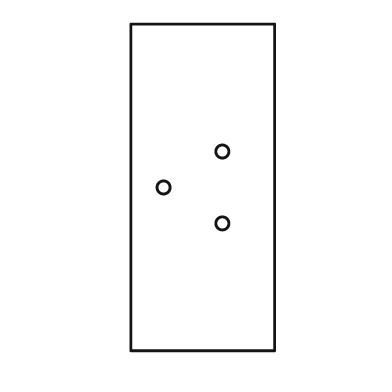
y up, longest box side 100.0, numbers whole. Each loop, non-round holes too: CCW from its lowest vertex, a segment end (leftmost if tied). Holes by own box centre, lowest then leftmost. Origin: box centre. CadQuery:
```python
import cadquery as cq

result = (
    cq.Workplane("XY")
    .moveTo(-22.0, -50.0)
    .lineTo(22.0, -50.0)
    .lineTo(22.0, 50.0)
    .lineTo(-22.0, 50.0)
    .close()
    .moveTo(6.0, -11.0)
    .circle(2.0)
    .moveTo(-12.0, 0.0)
    .circle(2.0)
    .moveTo(6.0, 11.0)
    .circle(2.0)
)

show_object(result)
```